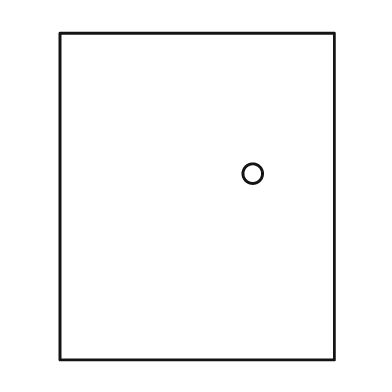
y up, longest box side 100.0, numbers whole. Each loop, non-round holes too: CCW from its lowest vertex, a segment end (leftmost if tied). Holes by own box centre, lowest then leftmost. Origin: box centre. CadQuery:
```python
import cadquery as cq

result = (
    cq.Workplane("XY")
    .moveTo(-42.0, -50.0)
    .lineTo(42.0, -50.0)
    .lineTo(42.0, 50.0)
    .lineTo(-42.0, 50.0)
    .close()
    .moveTo(17.0, 7.0)
    .circle(3.0)
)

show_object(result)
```